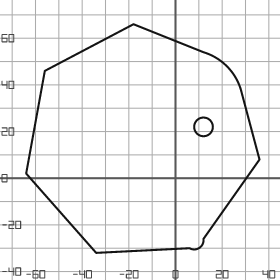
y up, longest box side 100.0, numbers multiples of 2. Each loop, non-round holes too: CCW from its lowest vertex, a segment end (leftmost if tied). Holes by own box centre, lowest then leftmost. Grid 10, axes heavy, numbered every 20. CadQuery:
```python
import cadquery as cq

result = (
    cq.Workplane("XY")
    .moveTo(-34.0, -32.0)
    .lineTo(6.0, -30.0)
    .threePointArc((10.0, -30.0), (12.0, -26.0))
    .lineTo(36.0, 8.0)
    .lineTo(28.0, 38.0)
    .threePointArc((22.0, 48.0), (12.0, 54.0))
    .lineTo(-18.0, 66.0)
    .lineTo(-56.0, 46.0)
    .lineTo(-64.0, 2.0)
    .close()
    .moveTo(12.0, 22.0)
    .circle(4.0)
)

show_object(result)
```